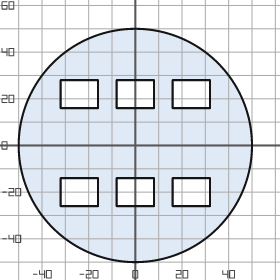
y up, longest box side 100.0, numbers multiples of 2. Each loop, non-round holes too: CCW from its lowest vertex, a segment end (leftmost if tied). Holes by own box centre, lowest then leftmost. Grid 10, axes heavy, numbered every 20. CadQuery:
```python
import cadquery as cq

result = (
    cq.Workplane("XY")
    .moveTo(0.0, 0.0)
    .circle(50.0)
    .moveTo(-32.0, -26.0)
    .lineTo(-16.0, -26.0)
    .lineTo(-16.0, -14.0)
    .lineTo(-32.0, -14.0)
    .close()
    .moveTo(-8.0, -26.0)
    .lineTo(8.0, -26.0)
    .lineTo(8.0, -14.0)
    .lineTo(-8.0, -14.0)
    .close()
    .moveTo(16.0, -26.0)
    .lineTo(32.0, -26.0)
    .lineTo(32.0, -14.0)
    .lineTo(16.0, -14.0)
    .close()
    .moveTo(-32.0, 16.0)
    .lineTo(-16.0, 16.0)
    .lineTo(-16.0, 28.0)
    .lineTo(-32.0, 28.0)
    .close()
    .moveTo(-8.0, 16.0)
    .lineTo(8.0, 16.0)
    .lineTo(8.0, 28.0)
    .lineTo(-8.0, 28.0)
    .close()
    .moveTo(16.0, 16.0)
    .lineTo(32.0, 16.0)
    .lineTo(32.0, 28.0)
    .lineTo(16.0, 28.0)
    .close()
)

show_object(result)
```